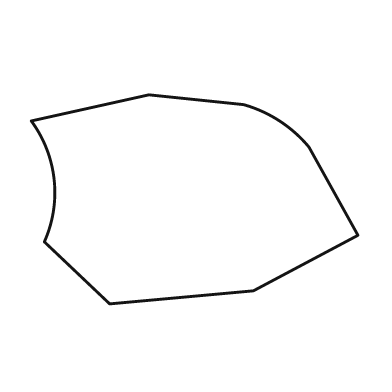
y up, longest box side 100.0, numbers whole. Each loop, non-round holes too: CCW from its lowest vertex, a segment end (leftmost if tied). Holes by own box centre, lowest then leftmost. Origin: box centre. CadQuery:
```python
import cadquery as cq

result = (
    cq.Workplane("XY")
    .moveTo(-26.0, -32.0)
    .lineTo(18.0, -28.0)
    .lineTo(50.0, -11.0)
    .lineTo(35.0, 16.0)
    .threePointArc((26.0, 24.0), (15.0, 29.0))
    .lineTo(-14.0, 32.0)
    .lineTo(-50.0, 24.0)
    .threePointArc((-43.0, 6.0), (-46.0, -13.0))
    .close()
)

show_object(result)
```